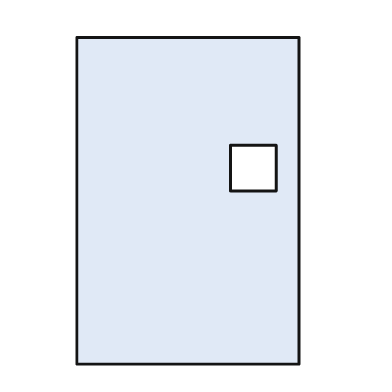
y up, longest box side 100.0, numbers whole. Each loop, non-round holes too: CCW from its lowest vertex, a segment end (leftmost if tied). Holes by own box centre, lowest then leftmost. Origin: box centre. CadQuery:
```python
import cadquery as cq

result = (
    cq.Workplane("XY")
    .moveTo(-34.0, -50.0)
    .lineTo(34.0, -50.0)
    .lineTo(34.0, 50.0)
    .lineTo(-34.0, 50.0)
    .close()
    .moveTo(13.0, 3.0)
    .lineTo(27.0, 3.0)
    .lineTo(27.0, 17.0)
    .lineTo(13.0, 17.0)
    .close()
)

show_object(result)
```